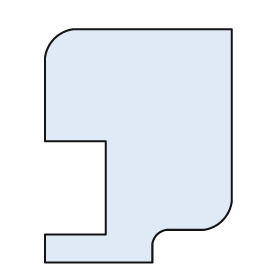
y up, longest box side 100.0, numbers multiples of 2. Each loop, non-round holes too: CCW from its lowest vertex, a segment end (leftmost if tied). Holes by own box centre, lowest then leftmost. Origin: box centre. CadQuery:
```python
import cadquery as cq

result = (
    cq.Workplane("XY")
    .moveTo(-40.0, -50.0)
    .lineTo(6.0, -50.0)
    .lineTo(6.0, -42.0)
    .threePointArc((8.0, -38.0), (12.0, -36.0))
    .lineTo(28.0, -36.0)
    .threePointArc((36.0, -32.0), (40.0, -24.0))
    .lineTo(40.0, 50.0)
    .lineTo(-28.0, 50.0)
    .threePointArc((-36.0, 46.0), (-40.0, 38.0))
    .lineTo(-40.0, 2.0)
    .lineTo(-14.0, 2.0)
    .lineTo(-14.0, -38.0)
    .lineTo(-40.0, -38.0)
    .close()
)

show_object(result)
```